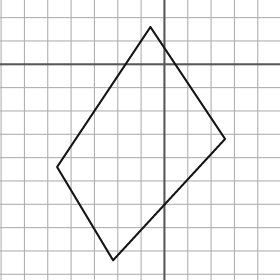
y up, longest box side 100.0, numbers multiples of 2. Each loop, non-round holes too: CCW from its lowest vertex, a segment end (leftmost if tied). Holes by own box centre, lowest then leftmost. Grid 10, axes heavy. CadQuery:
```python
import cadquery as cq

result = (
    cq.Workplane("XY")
    .moveTo(-22.0, -84.0)
    .lineTo(26.0, -32.0)
    .lineTo(-6.0, 16.0)
    .lineTo(-46.0, -44.0)
    .close()
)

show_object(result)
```